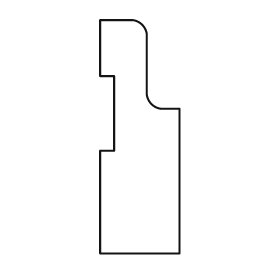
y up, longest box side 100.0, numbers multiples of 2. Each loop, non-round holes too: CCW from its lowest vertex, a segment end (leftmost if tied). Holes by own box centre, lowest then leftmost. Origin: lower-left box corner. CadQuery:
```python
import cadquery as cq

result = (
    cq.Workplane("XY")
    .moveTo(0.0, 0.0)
    .lineTo(34.0, 0.0)
    .lineTo(34.0, 62.0)
    .lineTo(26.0, 62.0)
    .threePointArc((22.0, 64.0), (20.0, 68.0))
    .lineTo(20.0, 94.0)
    .threePointArc((18.0, 98.0), (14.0, 100.0))
    .lineTo(0.0, 100.0)
    .lineTo(0.0, 76.0)
    .lineTo(6.0, 76.0)
    .lineTo(6.0, 44.0)
    .lineTo(0.0, 44.0)
    .close()
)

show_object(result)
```